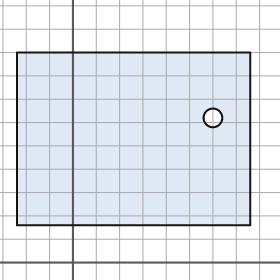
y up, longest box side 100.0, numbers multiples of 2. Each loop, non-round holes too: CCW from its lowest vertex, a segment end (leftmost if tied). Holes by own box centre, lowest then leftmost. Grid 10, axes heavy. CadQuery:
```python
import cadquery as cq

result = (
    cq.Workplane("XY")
    .moveTo(-24.0, 16.0)
    .lineTo(76.0, 16.0)
    .lineTo(76.0, 90.0)
    .lineTo(-24.0, 90.0)
    .close()
    .moveTo(60.0, 62.0)
    .circle(4.0)
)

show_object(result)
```